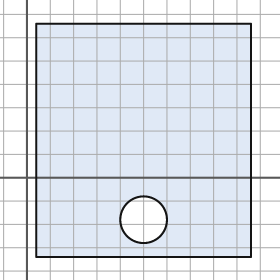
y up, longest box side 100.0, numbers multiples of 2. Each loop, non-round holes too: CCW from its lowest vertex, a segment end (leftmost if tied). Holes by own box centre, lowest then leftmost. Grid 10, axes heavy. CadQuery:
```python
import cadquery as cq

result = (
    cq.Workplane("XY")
    .moveTo(4.0, -34.0)
    .lineTo(96.0, -34.0)
    .lineTo(96.0, 66.0)
    .lineTo(4.0, 66.0)
    .close()
    .moveTo(50.0, -18.0)
    .circle(10.0)
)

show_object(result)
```